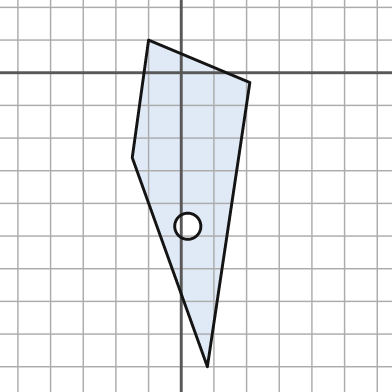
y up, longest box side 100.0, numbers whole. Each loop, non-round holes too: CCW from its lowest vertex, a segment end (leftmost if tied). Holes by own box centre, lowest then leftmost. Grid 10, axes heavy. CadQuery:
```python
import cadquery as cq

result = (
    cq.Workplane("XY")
    .moveTo(8.0, -90.0)
    .lineTo(21.0, -3.0)
    .lineTo(-10.0, 10.0)
    .lineTo(-15.0, -26.0)
    .close()
    .moveTo(2.0, -47.0)
    .circle(4.0)
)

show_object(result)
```